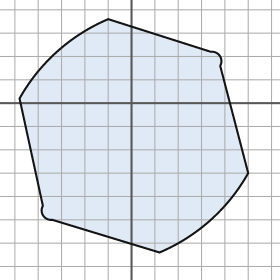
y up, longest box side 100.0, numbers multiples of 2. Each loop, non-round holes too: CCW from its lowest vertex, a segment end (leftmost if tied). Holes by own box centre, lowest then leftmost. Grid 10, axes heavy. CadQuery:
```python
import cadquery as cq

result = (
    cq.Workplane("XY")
    .moveTo(12.0, -64.0)
    .threePointArc((34.0, -50.0), (50.0, -30.0))
    .lineTo(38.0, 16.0)
    .threePointArc((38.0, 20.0), (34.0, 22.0))
    .lineTo(-10.0, 36.0)
    .threePointArc((-32.0, 22.0), (-48.0, 2.0))
    .lineTo(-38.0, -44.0)
    .threePointArc((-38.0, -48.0), (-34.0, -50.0))
    .close()
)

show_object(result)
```